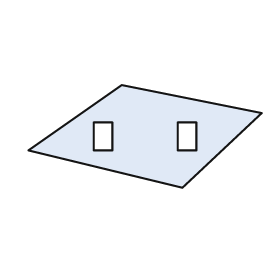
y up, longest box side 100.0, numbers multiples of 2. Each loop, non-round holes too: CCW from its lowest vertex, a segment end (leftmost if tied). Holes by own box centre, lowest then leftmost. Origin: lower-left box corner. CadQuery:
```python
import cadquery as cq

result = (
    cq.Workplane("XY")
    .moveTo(66.0, 0.0)
    .lineTo(100.0, 32.0)
    .lineTo(40.0, 44.0)
    .lineTo(0.0, 16.0)
    .close()
    .moveTo(28.0, 16.0)
    .lineTo(36.0, 16.0)
    .lineTo(36.0, 28.0)
    .lineTo(28.0, 28.0)
    .close()
    .moveTo(64.0, 16.0)
    .lineTo(72.0, 16.0)
    .lineTo(72.0, 28.0)
    .lineTo(64.0, 28.0)
    .close()
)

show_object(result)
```